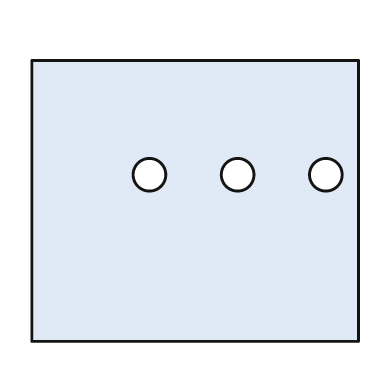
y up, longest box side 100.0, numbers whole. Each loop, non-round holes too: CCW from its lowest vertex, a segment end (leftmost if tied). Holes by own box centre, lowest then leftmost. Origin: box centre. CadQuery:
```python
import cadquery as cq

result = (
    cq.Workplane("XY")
    .moveTo(-50.0, -43.0)
    .lineTo(50.0, -43.0)
    .lineTo(50.0, 43.0)
    .lineTo(-50.0, 43.0)
    .close()
    .moveTo(-14.0, 8.0)
    .circle(5.0)
    .moveTo(13.0, 8.0)
    .circle(5.0)
    .moveTo(40.0, 8.0)
    .circle(5.0)
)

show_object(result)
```